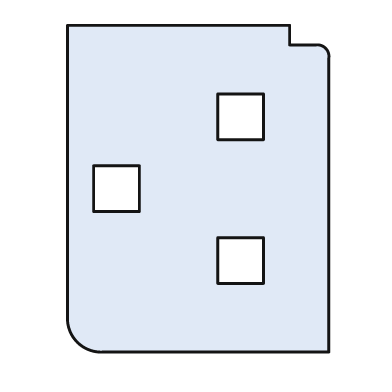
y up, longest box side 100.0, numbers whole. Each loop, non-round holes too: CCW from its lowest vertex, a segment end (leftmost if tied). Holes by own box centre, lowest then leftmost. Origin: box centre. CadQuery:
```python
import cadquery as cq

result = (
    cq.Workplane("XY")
    .moveTo(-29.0, -50.0)
    .lineTo(40.0, -50.0)
    .lineTo(40.0, 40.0)
    .threePointArc((39.0, 43.0), (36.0, 44.0))
    .lineTo(28.0, 44.0)
    .lineTo(28.0, 50.0)
    .lineTo(-40.0, 50.0)
    .lineTo(-40.0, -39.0)
    .threePointArc((-37.0, -47.0), (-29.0, -50.0))
    .close()
    .moveTo(6.0, -29.0)
    .lineTo(20.0, -29.0)
    .lineTo(20.0, -15.0)
    .lineTo(6.0, -15.0)
    .close()
    .moveTo(-32.0, -7.0)
    .lineTo(-18.0, -7.0)
    .lineTo(-18.0, 7.0)
    .lineTo(-32.0, 7.0)
    .close()
    .moveTo(6.0, 15.0)
    .lineTo(20.0, 15.0)
    .lineTo(20.0, 29.0)
    .lineTo(6.0, 29.0)
    .close()
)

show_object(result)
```